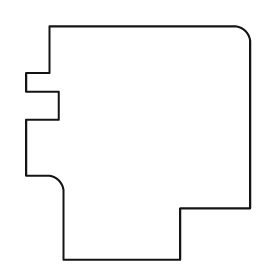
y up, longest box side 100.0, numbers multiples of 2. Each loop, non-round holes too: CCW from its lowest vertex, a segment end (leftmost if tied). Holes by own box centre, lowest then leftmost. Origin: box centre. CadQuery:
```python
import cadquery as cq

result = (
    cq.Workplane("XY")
    .moveTo(-32.0, -50.0)
    .lineTo(18.0, -50.0)
    .lineTo(18.0, -28.0)
    .lineTo(48.0, -28.0)
    .lineTo(48.0, 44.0)
    .threePointArc((46.0, 48.0), (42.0, 50.0))
    .lineTo(-38.0, 50.0)
    .lineTo(-38.0, 30.0)
    .lineTo(-48.0, 30.0)
    .lineTo(-48.0, 22.0)
    .lineTo(-34.0, 22.0)
    .lineTo(-34.0, 10.0)
    .lineTo(-48.0, 10.0)
    .lineTo(-48.0, -14.0)
    .lineTo(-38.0, -14.0)
    .threePointArc((-34.0, -16.0), (-32.0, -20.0))
    .close()
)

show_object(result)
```